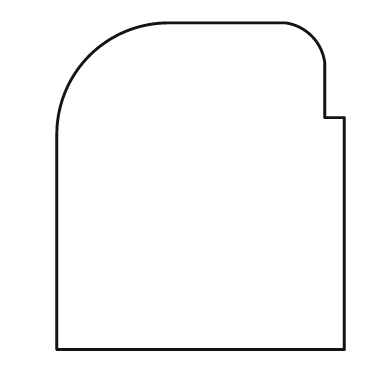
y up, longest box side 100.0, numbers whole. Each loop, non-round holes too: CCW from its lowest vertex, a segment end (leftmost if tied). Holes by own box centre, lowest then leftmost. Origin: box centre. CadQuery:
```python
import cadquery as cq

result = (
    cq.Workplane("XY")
    .moveTo(-44.0, -50.0)
    .lineTo(44.0, -50.0)
    .lineTo(44.0, 21.0)
    .lineTo(38.0, 21.0)
    .lineTo(38.0, 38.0)
    .threePointArc((34.0, 46.0), (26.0, 50.0))
    .lineTo(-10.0, 50.0)
    .threePointArc((-34.0, 40.0), (-44.0, 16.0))
    .close()
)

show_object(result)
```